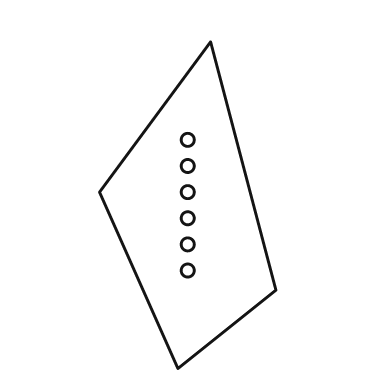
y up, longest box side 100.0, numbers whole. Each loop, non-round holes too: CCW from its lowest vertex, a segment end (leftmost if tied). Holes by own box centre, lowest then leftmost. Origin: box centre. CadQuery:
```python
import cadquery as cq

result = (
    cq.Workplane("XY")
    .moveTo(-3.0, -50.0)
    .lineTo(27.0, -26.0)
    .lineTo(7.0, 50.0)
    .lineTo(-27.0, 4.0)
    .close()
    .moveTo(0.0, -20.0)
    .circle(2.0)
    .moveTo(0.0, -12.0)
    .circle(2.0)
    .moveTo(0.0, -4.0)
    .circle(2.0)
    .moveTo(0.0, 4.0)
    .circle(2.0)
    .moveTo(0.0, 12.0)
    .circle(2.0)
    .moveTo(0.0, 20.0)
    .circle(2.0)
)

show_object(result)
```